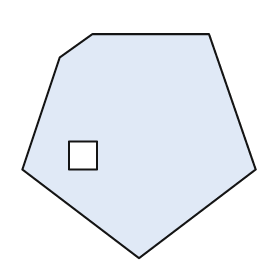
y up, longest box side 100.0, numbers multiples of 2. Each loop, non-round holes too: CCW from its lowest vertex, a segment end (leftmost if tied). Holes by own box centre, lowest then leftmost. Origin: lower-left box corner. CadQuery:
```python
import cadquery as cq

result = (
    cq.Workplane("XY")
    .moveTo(50.0, 0.0)
    .lineTo(100.0, 38.0)
    .lineTo(80.0, 96.0)
    .lineTo(30.0, 96.0)
    .lineTo(16.0, 86.0)
    .lineTo(0.0, 38.0)
    .close()
    .moveTo(20.0, 38.0)
    .lineTo(32.0, 38.0)
    .lineTo(32.0, 50.0)
    .lineTo(20.0, 50.0)
    .close()
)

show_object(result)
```